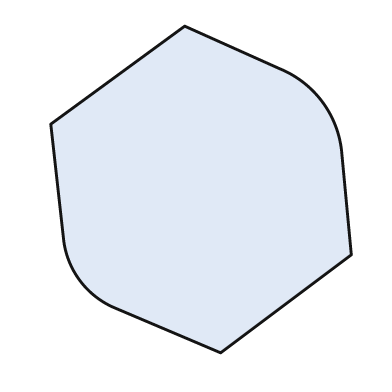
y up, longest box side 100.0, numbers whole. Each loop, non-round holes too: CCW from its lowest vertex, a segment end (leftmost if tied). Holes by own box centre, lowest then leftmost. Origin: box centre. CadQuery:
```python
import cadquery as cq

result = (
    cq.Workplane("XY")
    .moveTo(6.0, -50.0)
    .lineTo(46.0, -20.0)
    .lineTo(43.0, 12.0)
    .threePointArc((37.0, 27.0), (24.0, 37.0))
    .lineTo(-5.0, 50.0)
    .lineTo(-46.0, 20.0)
    .lineTo(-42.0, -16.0)
    .threePointArc((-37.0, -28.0), (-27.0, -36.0))
    .close()
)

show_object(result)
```